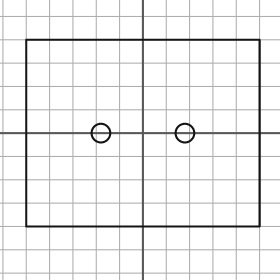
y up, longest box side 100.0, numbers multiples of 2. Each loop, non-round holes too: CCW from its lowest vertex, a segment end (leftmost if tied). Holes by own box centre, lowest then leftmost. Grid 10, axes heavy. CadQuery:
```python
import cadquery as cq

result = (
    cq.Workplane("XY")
    .moveTo(-50.0, -40.0)
    .lineTo(50.0, -40.0)
    .lineTo(50.0, 40.0)
    .lineTo(-50.0, 40.0)
    .close()
    .moveTo(-18.0, 0.0)
    .circle(4.0)
    .moveTo(18.0, 0.0)
    .circle(4.0)
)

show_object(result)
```